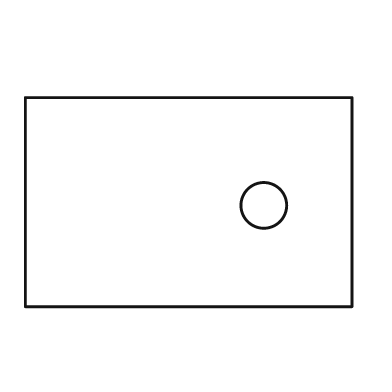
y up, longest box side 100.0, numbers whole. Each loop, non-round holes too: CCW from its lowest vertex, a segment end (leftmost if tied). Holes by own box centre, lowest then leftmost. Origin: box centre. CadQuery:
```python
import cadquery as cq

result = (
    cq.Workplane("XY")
    .moveTo(-50.0, -32.0)
    .lineTo(50.0, -32.0)
    .lineTo(50.0, 32.0)
    .lineTo(-50.0, 32.0)
    .close()
    .moveTo(23.0, -1.0)
    .circle(7.0)
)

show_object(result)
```